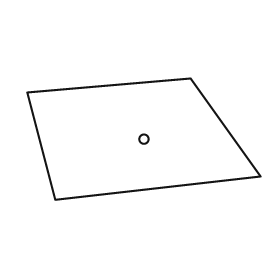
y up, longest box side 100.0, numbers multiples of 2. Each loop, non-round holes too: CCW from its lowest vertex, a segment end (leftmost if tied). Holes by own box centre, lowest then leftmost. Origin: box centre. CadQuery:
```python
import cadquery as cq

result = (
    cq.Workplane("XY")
    .moveTo(-38.0, -26.0)
    .lineTo(50.0, -16.0)
    .lineTo(20.0, 26.0)
    .lineTo(-50.0, 20.0)
    .close()
    .moveTo(0.0, 0.0)
    .circle(2.0)
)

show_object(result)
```